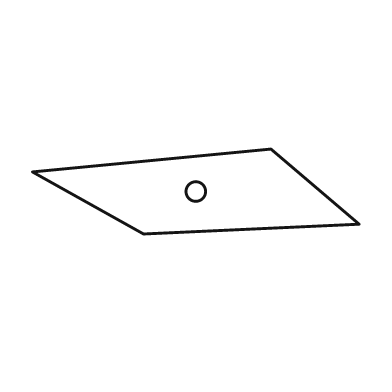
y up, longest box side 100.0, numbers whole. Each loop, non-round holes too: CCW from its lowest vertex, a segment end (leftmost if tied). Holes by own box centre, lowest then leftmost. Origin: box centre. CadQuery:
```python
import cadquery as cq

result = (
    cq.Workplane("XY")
    .moveTo(-16.0, -13.0)
    .lineTo(50.0, -10.0)
    .lineTo(23.0, 13.0)
    .lineTo(-50.0, 6.0)
    .close()
    .moveTo(0.0, 0.0)
    .circle(3.0)
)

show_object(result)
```